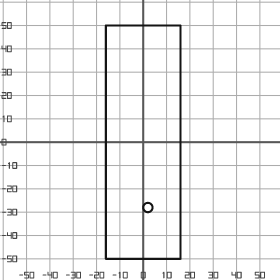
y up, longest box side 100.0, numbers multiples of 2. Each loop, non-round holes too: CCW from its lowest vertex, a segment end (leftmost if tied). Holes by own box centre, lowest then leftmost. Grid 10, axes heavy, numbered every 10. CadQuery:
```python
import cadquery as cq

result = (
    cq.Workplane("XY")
    .moveTo(-16.0, -50.0)
    .lineTo(16.0, -50.0)
    .lineTo(16.0, 50.0)
    .lineTo(-16.0, 50.0)
    .close()
    .moveTo(2.0, -28.0)
    .circle(2.0)
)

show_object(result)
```